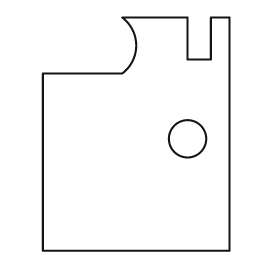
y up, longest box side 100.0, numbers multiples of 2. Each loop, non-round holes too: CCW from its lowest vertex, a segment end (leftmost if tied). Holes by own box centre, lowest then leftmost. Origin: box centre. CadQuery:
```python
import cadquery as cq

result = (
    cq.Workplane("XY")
    .moveTo(-40.0, -50.0)
    .lineTo(40.0, -50.0)
    .lineTo(40.0, 50.0)
    .lineTo(32.0, 50.0)
    .lineTo(32.0, 32.0)
    .lineTo(22.0, 32.0)
    .lineTo(22.0, 50.0)
    .lineTo(-6.0, 50.0)
    .threePointArc((0.0, 38.0), (-6.0, 26.0))
    .lineTo(-40.0, 26.0)
    .close()
    .moveTo(22.0, -2.0)
    .circle(8.0)
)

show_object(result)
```